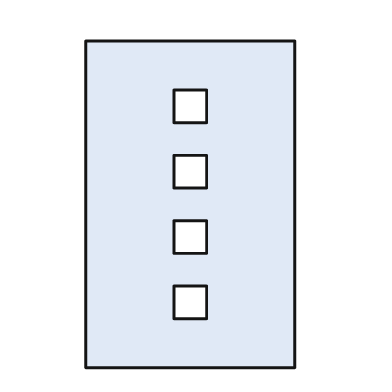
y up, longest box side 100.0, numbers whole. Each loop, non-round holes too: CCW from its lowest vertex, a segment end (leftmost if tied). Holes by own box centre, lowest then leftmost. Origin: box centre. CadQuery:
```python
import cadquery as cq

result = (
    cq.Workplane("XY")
    .moveTo(-32.0, -50.0)
    .lineTo(32.0, -50.0)
    .lineTo(32.0, 50.0)
    .lineTo(-32.0, 50.0)
    .close()
    .moveTo(-5.0, -35.0)
    .lineTo(5.0, -35.0)
    .lineTo(5.0, -25.0)
    .lineTo(-5.0, -25.0)
    .close()
    .moveTo(-5.0, -15.0)
    .lineTo(5.0, -15.0)
    .lineTo(5.0, -5.0)
    .lineTo(-5.0, -5.0)
    .close()
    .moveTo(-5.0, 5.0)
    .lineTo(5.0, 5.0)
    .lineTo(5.0, 15.0)
    .lineTo(-5.0, 15.0)
    .close()
    .moveTo(-5.0, 25.0)
    .lineTo(5.0, 25.0)
    .lineTo(5.0, 35.0)
    .lineTo(-5.0, 35.0)
    .close()
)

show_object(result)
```